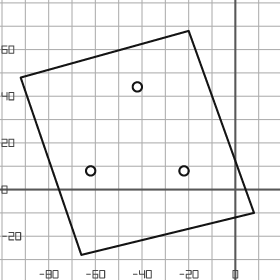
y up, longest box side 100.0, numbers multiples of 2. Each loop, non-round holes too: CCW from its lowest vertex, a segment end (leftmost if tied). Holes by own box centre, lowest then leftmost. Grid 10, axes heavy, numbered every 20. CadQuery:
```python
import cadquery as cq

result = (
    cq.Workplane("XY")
    .moveTo(-66.0, -28.0)
    .lineTo(8.0, -10.0)
    .lineTo(-20.0, 68.0)
    .lineTo(-92.0, 48.0)
    .close()
    .moveTo(-62.0, 8.0)
    .circle(2.0)
    .moveTo(-22.0, 8.0)
    .circle(2.0)
    .moveTo(-42.0, 44.0)
    .circle(2.0)
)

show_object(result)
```